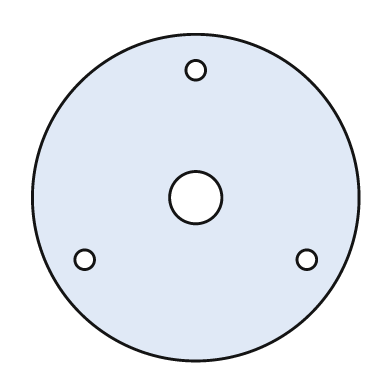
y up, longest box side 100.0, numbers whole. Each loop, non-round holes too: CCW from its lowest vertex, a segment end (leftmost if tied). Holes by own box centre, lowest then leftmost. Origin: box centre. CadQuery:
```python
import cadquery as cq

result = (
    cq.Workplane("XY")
    .moveTo(0.0, 0.0)
    .circle(50.0)
    .moveTo(-34.0, -19.0)
    .circle(3.0)
    .moveTo(34.0, -19.0)
    .circle(3.0)
    .moveTo(0.0, 0.0)
    .circle(8.0)
    .moveTo(0.0, 39.0)
    .circle(3.0)
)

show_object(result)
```